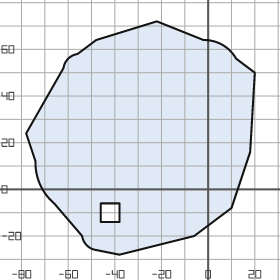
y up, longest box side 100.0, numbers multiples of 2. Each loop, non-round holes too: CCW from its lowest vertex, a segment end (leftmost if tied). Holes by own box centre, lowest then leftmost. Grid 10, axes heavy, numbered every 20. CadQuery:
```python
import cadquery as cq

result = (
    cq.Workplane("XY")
    .moveTo(-38.0, -28.0)
    .lineTo(-6.0, -20.0)
    .lineTo(10.0, -8.0)
    .lineTo(18.0, 16.0)
    .lineTo(20.0, 50.0)
    .lineTo(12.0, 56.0)
    .threePointArc((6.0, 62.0), (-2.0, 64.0))
    .lineTo(-22.0, 72.0)
    .lineTo(-48.0, 64.0)
    .lineTo(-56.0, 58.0)
    .threePointArc((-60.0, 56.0), (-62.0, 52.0))
    .lineTo(-78.0, 24.0)
    .lineTo(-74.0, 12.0)
    .threePointArc((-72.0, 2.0), (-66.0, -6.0))
    .lineTo(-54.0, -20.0)
    .threePointArc((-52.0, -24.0), (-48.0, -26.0))
    .close()
    .moveTo(-46.0, -14.0)
    .lineTo(-38.0, -14.0)
    .lineTo(-38.0, -6.0)
    .lineTo(-46.0, -6.0)
    .close()
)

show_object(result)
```